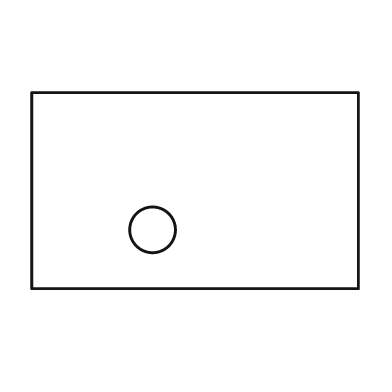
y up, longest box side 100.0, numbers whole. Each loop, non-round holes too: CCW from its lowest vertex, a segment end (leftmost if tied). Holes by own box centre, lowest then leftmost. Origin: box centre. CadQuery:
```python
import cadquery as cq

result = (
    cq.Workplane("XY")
    .moveTo(-50.0, -30.0)
    .lineTo(50.0, -30.0)
    .lineTo(50.0, 30.0)
    .lineTo(-50.0, 30.0)
    .close()
    .moveTo(-13.0, -12.0)
    .circle(7.0)
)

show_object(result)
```